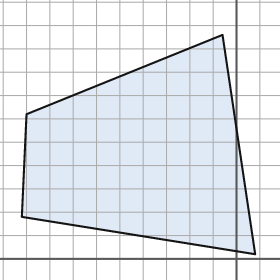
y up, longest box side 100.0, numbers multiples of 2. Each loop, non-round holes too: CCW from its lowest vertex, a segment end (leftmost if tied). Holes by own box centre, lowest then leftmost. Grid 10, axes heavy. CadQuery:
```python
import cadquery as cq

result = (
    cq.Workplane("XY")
    .moveTo(8.0, 2.0)
    .lineTo(-6.0, 96.0)
    .lineTo(-90.0, 62.0)
    .lineTo(-92.0, 18.0)
    .close()
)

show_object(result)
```